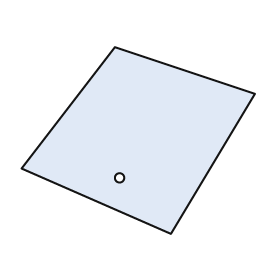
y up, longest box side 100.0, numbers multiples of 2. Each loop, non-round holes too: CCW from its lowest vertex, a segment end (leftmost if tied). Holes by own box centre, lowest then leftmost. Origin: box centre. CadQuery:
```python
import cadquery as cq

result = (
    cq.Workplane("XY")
    .moveTo(14.0, -40.0)
    .lineTo(50.0, 20.0)
    .lineTo(-10.0, 40.0)
    .lineTo(-50.0, -12.0)
    .close()
    .moveTo(-8.0, -16.0)
    .circle(2.0)
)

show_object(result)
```